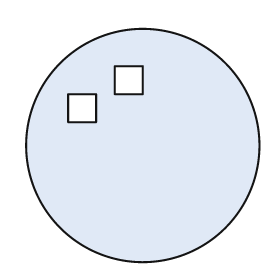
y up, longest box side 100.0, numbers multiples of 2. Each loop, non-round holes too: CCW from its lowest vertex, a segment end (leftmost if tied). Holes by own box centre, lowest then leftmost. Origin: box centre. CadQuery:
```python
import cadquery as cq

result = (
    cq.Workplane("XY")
    .moveTo(0.0, 0.0)
    .circle(50.0)
    .moveTo(-32.0, 10.0)
    .lineTo(-20.0, 10.0)
    .lineTo(-20.0, 22.0)
    .lineTo(-32.0, 22.0)
    .close()
    .moveTo(-12.0, 22.0)
    .lineTo(0.0, 22.0)
    .lineTo(0.0, 34.0)
    .lineTo(-12.0, 34.0)
    .close()
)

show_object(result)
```